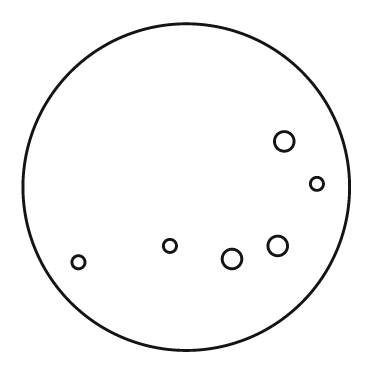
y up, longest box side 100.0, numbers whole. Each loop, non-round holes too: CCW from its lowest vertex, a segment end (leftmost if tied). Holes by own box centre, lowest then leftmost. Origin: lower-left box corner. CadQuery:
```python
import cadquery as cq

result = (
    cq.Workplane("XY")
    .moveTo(50.0, 50.0)
    .circle(50.0)
    .moveTo(17.0, 27.0)
    .circle(2.0)
    .moveTo(64.0, 28.0)
    .circle(3.0)
    .moveTo(45.0, 32.0)
    .circle(2.0)
    .moveTo(78.0, 32.0)
    .circle(3.0)
    .moveTo(90.0, 51.0)
    .circle(2.0)
    .moveTo(80.0, 64.0)
    .circle(3.0)
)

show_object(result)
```